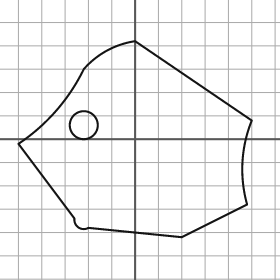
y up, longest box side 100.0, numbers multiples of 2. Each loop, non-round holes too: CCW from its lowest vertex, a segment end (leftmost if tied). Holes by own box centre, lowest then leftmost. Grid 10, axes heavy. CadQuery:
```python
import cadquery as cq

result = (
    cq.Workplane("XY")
    .moveTo(20.0, -42.0)
    .lineTo(48.0, -28.0)
    .threePointArc((46.0, -10.0), (50.0, 8.0))
    .lineTo(0.0, 42.0)
    .threePointArc((-12.0, 38.0), (-22.0, 30.0))
    .threePointArc((-34.0, 12.0), (-50.0, -2.0))
    .lineTo(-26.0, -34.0)
    .threePointArc((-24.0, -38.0), (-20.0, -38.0))
    .close()
    .moveTo(-22.0, 6.0)
    .circle(6.0)
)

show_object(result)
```